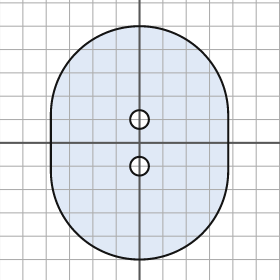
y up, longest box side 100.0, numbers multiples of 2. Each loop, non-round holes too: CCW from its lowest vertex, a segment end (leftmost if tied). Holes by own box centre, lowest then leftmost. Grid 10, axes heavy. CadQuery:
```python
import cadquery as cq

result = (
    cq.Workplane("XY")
    .moveTo(-38.0, -12.0)
    .threePointArc((0.0, -50.0), (38.0, -12.0))
    .lineTo(38.0, 12.0)
    .threePointArc((0.0, 50.0), (-38.0, 12.0))
    .close()
    .moveTo(0.0, -10.0)
    .circle(4.0)
    .moveTo(0.0, 10.0)
    .circle(4.0)
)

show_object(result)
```